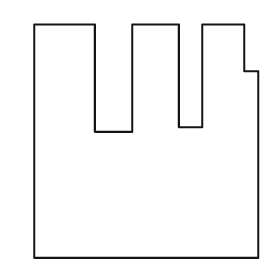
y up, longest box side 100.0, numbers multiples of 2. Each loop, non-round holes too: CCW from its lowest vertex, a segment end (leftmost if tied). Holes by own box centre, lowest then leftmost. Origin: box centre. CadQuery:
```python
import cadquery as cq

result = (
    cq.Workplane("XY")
    .moveTo(-48.0, -50.0)
    .lineTo(48.0, -50.0)
    .lineTo(48.0, 30.0)
    .lineTo(42.0, 30.0)
    .lineTo(42.0, 50.0)
    .lineTo(24.0, 50.0)
    .lineTo(24.0, 6.0)
    .lineTo(14.0, 6.0)
    .lineTo(14.0, 50.0)
    .lineTo(-6.0, 50.0)
    .lineTo(-6.0, 4.0)
    .lineTo(-22.0, 4.0)
    .lineTo(-22.0, 50.0)
    .lineTo(-48.0, 50.0)
    .close()
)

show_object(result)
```